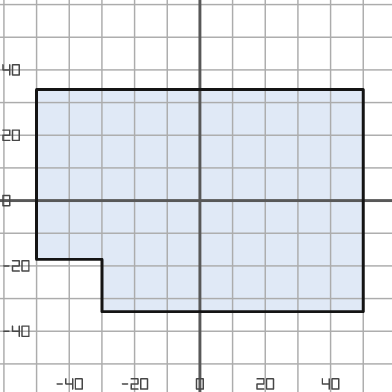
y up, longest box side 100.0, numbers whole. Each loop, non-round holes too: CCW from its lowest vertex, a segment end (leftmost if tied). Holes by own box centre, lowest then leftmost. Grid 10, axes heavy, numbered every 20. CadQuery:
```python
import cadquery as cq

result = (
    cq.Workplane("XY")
    .moveTo(-30.0, -34.0)
    .lineTo(50.0, -34.0)
    .lineTo(50.0, 34.0)
    .lineTo(-50.0, 34.0)
    .lineTo(-50.0, -18.0)
    .lineTo(-30.0, -18.0)
    .close()
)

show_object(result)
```